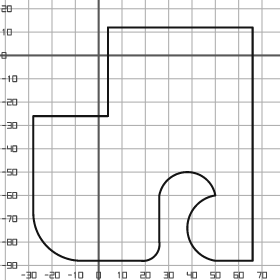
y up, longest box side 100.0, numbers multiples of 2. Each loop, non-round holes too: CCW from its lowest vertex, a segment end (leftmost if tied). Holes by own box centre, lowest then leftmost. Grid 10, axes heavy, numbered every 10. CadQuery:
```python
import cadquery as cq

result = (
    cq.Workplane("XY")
    .moveTo(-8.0, -88.0)
    .lineTo(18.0, -88.0)
    .threePointArc((24.0, -86.0), (26.0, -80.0))
    .lineTo(26.0, -60.0)
    .threePointArc((38.0, -50.0), (50.0, -60.0))
    .threePointArc((38.0, -74.0), (50.0, -88.0))
    .lineTo(66.0, -88.0)
    .lineTo(66.0, 12.0)
    .lineTo(4.0, 12.0)
    .lineTo(4.0, -26.0)
    .lineTo(-28.0, -26.0)
    .lineTo(-28.0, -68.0)
    .threePointArc((-22.0, -82.0), (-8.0, -88.0))
    .close()
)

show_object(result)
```